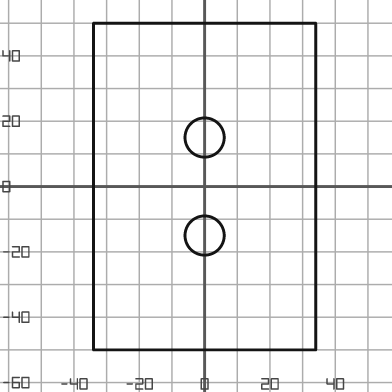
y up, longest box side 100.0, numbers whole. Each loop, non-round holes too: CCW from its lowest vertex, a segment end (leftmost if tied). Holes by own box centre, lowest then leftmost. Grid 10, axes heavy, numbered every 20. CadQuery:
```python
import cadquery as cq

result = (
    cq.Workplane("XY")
    .moveTo(-34.0, -50.0)
    .lineTo(34.0, -50.0)
    .lineTo(34.0, 50.0)
    .lineTo(-34.0, 50.0)
    .close()
    .moveTo(0.0, -15.0)
    .circle(6.0)
    .moveTo(0.0, 15.0)
    .circle(6.0)
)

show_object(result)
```